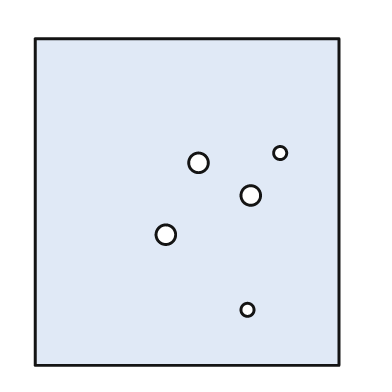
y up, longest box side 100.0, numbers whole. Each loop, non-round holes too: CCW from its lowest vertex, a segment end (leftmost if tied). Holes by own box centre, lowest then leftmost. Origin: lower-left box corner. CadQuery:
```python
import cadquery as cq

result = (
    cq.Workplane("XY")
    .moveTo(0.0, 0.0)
    .lineTo(93.0, 0.0)
    .lineTo(93.0, 100.0)
    .lineTo(0.0, 100.0)
    .close()
    .moveTo(65.0, 17.0)
    .circle(2.0)
    .moveTo(40.0, 40.0)
    .circle(3.0)
    .moveTo(66.0, 52.0)
    .circle(3.0)
    .moveTo(50.0, 62.0)
    .circle(3.0)
    .moveTo(75.0, 65.0)
    .circle(2.0)
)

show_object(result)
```